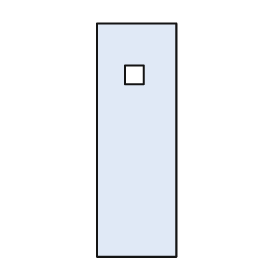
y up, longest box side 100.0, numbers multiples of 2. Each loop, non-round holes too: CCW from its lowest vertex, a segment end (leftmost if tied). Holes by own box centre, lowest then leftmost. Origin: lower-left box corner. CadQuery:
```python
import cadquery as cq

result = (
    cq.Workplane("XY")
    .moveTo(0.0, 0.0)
    .lineTo(34.0, 0.0)
    .lineTo(34.0, 100.0)
    .lineTo(0.0, 100.0)
    .close()
    .moveTo(12.0, 74.0)
    .lineTo(20.0, 74.0)
    .lineTo(20.0, 82.0)
    .lineTo(12.0, 82.0)
    .close()
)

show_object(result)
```